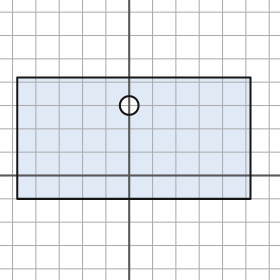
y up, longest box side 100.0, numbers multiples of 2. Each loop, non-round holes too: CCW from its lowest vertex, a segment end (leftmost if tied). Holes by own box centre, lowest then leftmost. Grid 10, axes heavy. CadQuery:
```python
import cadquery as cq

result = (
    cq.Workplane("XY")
    .moveTo(-48.0, -10.0)
    .lineTo(52.0, -10.0)
    .lineTo(52.0, 42.0)
    .lineTo(-48.0, 42.0)
    .close()
    .moveTo(0.0, 30.0)
    .circle(4.0)
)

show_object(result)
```